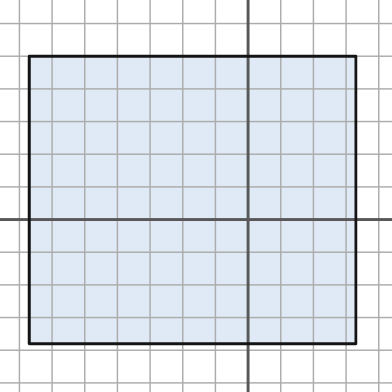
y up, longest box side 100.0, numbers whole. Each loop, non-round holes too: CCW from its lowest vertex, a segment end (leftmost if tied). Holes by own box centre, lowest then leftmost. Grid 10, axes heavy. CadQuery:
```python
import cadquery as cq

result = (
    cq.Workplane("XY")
    .moveTo(-67.0, -38.0)
    .lineTo(33.0, -38.0)
    .lineTo(33.0, 50.0)
    .lineTo(-67.0, 50.0)
    .close()
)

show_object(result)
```